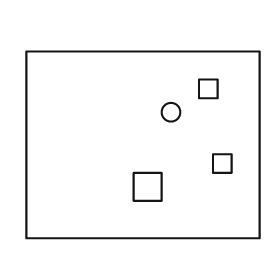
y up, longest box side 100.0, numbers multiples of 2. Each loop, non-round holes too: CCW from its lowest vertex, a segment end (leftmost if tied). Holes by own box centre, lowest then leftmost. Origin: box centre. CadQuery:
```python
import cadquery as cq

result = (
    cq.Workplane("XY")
    .moveTo(-50.0, -40.0)
    .lineTo(50.0, -40.0)
    .lineTo(50.0, 40.0)
    .lineTo(-50.0, 40.0)
    .close()
    .moveTo(-4.0, -24.0)
    .lineTo(8.0, -24.0)
    .lineTo(8.0, -12.0)
    .lineTo(-4.0, -12.0)
    .close()
    .moveTo(30.0, -12.0)
    .lineTo(38.0, -12.0)
    .lineTo(38.0, -4.0)
    .lineTo(30.0, -4.0)
    .close()
    .moveTo(12.0, 14.0)
    .circle(4.0)
    .moveTo(24.0, 20.0)
    .lineTo(32.0, 20.0)
    .lineTo(32.0, 28.0)
    .lineTo(24.0, 28.0)
    .close()
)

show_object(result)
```